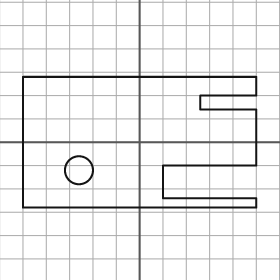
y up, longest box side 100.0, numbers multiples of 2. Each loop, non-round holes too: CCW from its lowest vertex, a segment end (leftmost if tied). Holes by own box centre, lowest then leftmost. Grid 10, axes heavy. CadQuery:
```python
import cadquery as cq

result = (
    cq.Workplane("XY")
    .moveTo(-50.0, -28.0)
    .lineTo(50.0, -28.0)
    .lineTo(50.0, -24.0)
    .lineTo(10.0, -24.0)
    .lineTo(10.0, -10.0)
    .lineTo(50.0, -10.0)
    .lineTo(50.0, 14.0)
    .lineTo(26.0, 14.0)
    .lineTo(26.0, 20.0)
    .lineTo(50.0, 20.0)
    .lineTo(50.0, 28.0)
    .lineTo(-50.0, 28.0)
    .close()
    .moveTo(-26.0, -12.0)
    .circle(6.0)
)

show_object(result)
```